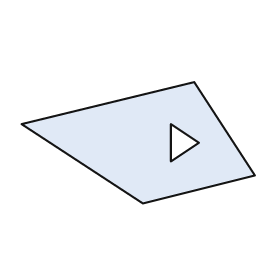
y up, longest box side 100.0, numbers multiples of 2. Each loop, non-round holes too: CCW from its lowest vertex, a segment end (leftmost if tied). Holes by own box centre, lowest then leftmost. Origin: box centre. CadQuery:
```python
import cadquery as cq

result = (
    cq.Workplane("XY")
    .moveTo(2.0, -26.0)
    .lineTo(50.0, -14.0)
    .lineTo(24.0, 26.0)
    .lineTo(-50.0, 8.0)
    .close()
    .moveTo(14.0, -8.0)
    .lineTo(26.0, 0.0)
    .lineTo(14.0, 8.0)
    .close()
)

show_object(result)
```